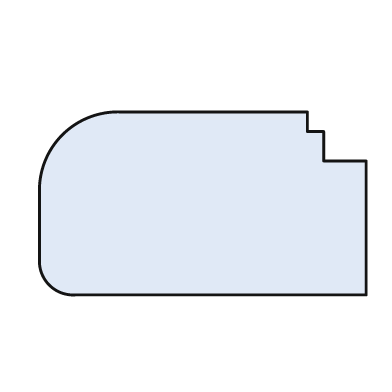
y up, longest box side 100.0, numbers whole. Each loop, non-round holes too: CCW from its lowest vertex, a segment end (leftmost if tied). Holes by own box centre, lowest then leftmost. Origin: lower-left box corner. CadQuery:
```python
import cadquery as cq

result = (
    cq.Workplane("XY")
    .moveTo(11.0, 0.0)
    .lineTo(100.0, 0.0)
    .lineTo(100.0, 41.0)
    .lineTo(87.0, 41.0)
    .lineTo(87.0, 50.0)
    .lineTo(82.0, 50.0)
    .lineTo(82.0, 56.0)
    .lineTo(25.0, 56.0)
    .threePointArc((7.0, 49.0), (0.0, 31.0))
    .lineTo(0.0, 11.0)
    .threePointArc((3.0, 3.0), (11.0, 0.0))
    .close()
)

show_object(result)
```